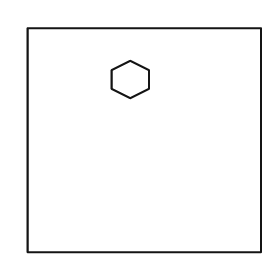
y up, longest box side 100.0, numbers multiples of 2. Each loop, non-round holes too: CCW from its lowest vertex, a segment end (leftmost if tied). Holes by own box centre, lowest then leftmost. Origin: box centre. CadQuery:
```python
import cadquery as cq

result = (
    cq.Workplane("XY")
    .moveTo(-50.0, -48.0)
    .lineTo(50.0, -48.0)
    .lineTo(50.0, 48.0)
    .lineTo(-50.0, 48.0)
    .close()
    .moveTo(-6.0, 18.0)
    .lineTo(2.0, 22.0)
    .lineTo(2.0, 30.0)
    .lineTo(-6.0, 34.0)
    .lineTo(-14.0, 30.0)
    .lineTo(-14.0, 22.0)
    .close()
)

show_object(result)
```